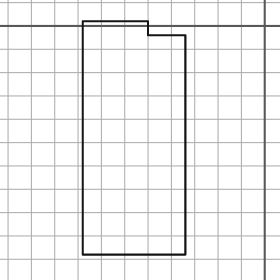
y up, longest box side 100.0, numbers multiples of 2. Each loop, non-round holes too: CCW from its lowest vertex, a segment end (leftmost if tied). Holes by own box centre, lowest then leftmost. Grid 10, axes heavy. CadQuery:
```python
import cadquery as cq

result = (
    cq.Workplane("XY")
    .moveTo(-78.0, -98.0)
    .lineTo(-34.0, -98.0)
    .lineTo(-34.0, -4.0)
    .lineTo(-50.0, -4.0)
    .lineTo(-50.0, 2.0)
    .lineTo(-78.0, 2.0)
    .close()
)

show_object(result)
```